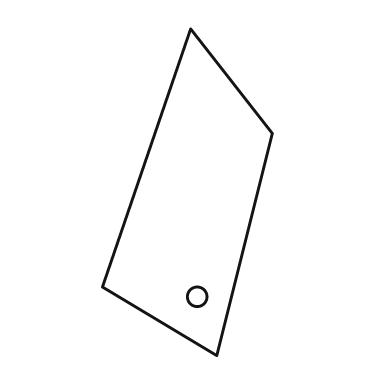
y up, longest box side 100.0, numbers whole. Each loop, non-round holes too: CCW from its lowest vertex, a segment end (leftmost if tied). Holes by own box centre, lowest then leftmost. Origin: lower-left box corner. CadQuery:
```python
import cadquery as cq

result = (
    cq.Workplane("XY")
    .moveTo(35.0, 0.0)
    .lineTo(52.0, 68.0)
    .lineTo(27.0, 100.0)
    .lineTo(0.0, 21.0)
    .close()
    .moveTo(29.0, 18.0)
    .circle(3.0)
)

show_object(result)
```